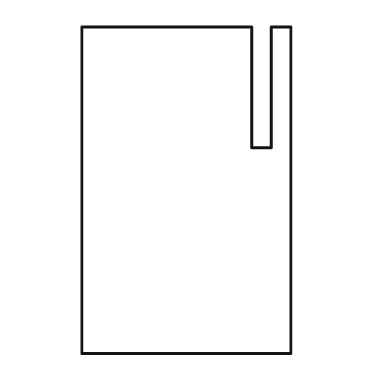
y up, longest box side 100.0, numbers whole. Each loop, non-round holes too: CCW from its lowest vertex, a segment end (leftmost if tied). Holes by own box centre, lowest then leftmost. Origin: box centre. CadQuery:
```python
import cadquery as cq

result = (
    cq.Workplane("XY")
    .moveTo(-32.0, -50.0)
    .lineTo(32.0, -50.0)
    .lineTo(32.0, 50.0)
    .lineTo(26.0, 50.0)
    .lineTo(26.0, 13.0)
    .lineTo(20.0, 13.0)
    .lineTo(20.0, 50.0)
    .lineTo(-32.0, 50.0)
    .close()
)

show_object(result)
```